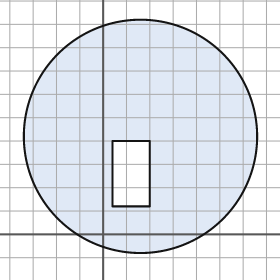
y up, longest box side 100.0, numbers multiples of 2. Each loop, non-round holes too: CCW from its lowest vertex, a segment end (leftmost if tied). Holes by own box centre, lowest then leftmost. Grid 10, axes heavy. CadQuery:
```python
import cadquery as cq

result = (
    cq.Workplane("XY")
    .moveTo(16.0, 42.0)
    .circle(50.0)
    .moveTo(4.0, 12.0)
    .lineTo(20.0, 12.0)
    .lineTo(20.0, 40.0)
    .lineTo(4.0, 40.0)
    .close()
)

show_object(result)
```